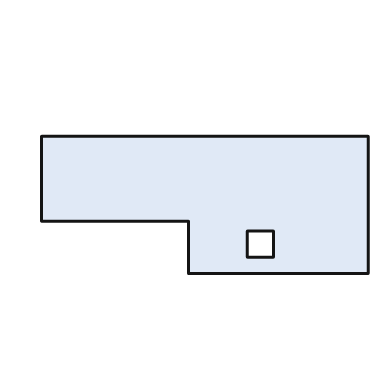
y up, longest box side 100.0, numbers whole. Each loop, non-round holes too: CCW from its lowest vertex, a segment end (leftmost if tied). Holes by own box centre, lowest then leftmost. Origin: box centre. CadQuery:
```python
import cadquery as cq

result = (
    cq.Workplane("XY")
    .moveTo(-5.0, -21.0)
    .lineTo(50.0, -21.0)
    .lineTo(50.0, 21.0)
    .lineTo(-50.0, 21.0)
    .lineTo(-50.0, -5.0)
    .lineTo(-5.0, -5.0)
    .close()
    .moveTo(13.0, -16.0)
    .lineTo(21.0, -16.0)
    .lineTo(21.0, -8.0)
    .lineTo(13.0, -8.0)
    .close()
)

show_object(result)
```